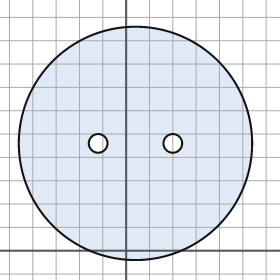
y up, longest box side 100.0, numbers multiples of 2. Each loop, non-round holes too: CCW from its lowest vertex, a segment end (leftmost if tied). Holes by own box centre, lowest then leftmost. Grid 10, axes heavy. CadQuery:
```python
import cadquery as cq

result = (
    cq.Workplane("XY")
    .moveTo(4.0, 46.0)
    .circle(50.0)
    .moveTo(-12.0, 46.0)
    .circle(4.0)
    .moveTo(20.0, 46.0)
    .circle(4.0)
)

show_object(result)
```